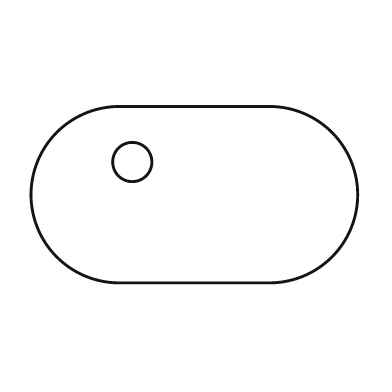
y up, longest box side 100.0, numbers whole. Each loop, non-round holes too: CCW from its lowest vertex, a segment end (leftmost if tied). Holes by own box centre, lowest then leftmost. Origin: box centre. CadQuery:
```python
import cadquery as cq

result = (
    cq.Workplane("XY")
    .moveTo(-23.0, -27.0)
    .lineTo(23.0, -27.0)
    .threePointArc((50.0, 0.0), (23.0, 27.0))
    .lineTo(-23.0, 27.0)
    .threePointArc((-50.0, 0.0), (-23.0, -27.0))
    .close()
    .moveTo(-19.0, 10.0)
    .circle(6.0)
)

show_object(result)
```